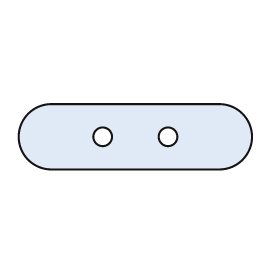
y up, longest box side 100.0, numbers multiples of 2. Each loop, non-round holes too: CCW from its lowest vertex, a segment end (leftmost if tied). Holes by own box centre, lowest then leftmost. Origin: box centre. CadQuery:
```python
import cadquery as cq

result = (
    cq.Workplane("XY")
    .moveTo(-36.0, -14.0)
    .lineTo(36.0, -14.0)
    .threePointArc((50.0, 0.0), (36.0, 14.0))
    .lineTo(-36.0, 14.0)
    .threePointArc((-50.0, 0.0), (-36.0, -14.0))
    .close()
    .moveTo(-14.0, 0.0)
    .circle(4.0)
    .moveTo(14.0, 0.0)
    .circle(4.0)
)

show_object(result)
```